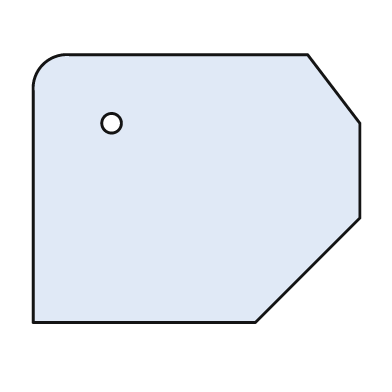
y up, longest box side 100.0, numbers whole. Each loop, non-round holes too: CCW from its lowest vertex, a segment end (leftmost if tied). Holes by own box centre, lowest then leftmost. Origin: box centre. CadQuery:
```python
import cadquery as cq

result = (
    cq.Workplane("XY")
    .moveTo(-50.0, -41.0)
    .lineTo(18.0, -41.0)
    .lineTo(50.0, -9.0)
    .lineTo(50.0, 20.0)
    .lineTo(34.0, 41.0)
    .lineTo(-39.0, 41.0)
    .threePointArc((-47.0, 38.0), (-50.0, 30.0))
    .close()
    .moveTo(-26.0, 20.0)
    .circle(3.0)
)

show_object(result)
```